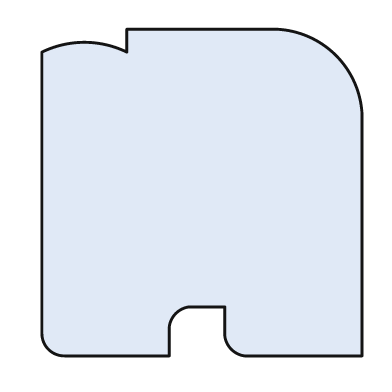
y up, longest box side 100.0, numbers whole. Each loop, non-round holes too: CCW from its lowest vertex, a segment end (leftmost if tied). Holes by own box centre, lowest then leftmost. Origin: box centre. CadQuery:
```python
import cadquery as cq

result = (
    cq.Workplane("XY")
    .moveTo(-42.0, -50.0)
    .lineTo(-10.0, -50.0)
    .lineTo(-10.0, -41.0)
    .threePointArc((-8.0, -37.0), (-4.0, -35.0))
    .lineTo(7.0, -35.0)
    .lineTo(7.0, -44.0)
    .threePointArc((9.0, -48.0), (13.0, -50.0))
    .lineTo(49.0, -50.0)
    .lineTo(49.0, 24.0)
    .threePointArc((41.0, 42.0), (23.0, 50.0))
    .lineTo(-23.0, 50.0)
    .lineTo(-23.0, 43.0)
    .threePointArc((-36.0, 46.0), (-49.0, 43.0))
    .lineTo(-49.0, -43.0)
    .threePointArc((-47.0, -48.0), (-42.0, -50.0))
    .close()
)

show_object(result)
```